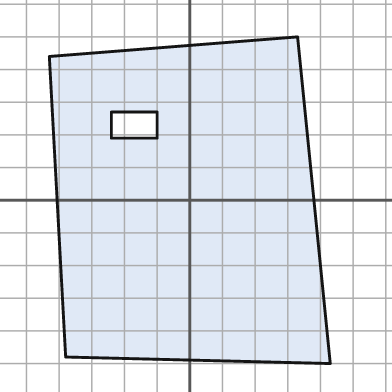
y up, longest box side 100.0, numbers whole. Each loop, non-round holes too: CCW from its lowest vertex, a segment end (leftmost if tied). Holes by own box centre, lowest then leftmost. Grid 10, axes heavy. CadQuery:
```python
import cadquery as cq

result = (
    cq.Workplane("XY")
    .moveTo(43.0, -50.0)
    .lineTo(33.0, 50.0)
    .lineTo(-43.0, 44.0)
    .lineTo(-38.0, -48.0)
    .close()
    .moveTo(-24.0, 19.0)
    .lineTo(-10.0, 19.0)
    .lineTo(-10.0, 27.0)
    .lineTo(-24.0, 27.0)
    .close()
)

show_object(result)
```